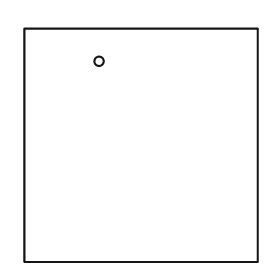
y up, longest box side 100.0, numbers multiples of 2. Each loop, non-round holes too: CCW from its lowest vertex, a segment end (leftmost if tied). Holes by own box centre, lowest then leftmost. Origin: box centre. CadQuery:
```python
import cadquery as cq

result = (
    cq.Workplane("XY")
    .moveTo(-50.0, -50.0)
    .lineTo(50.0, -50.0)
    .lineTo(50.0, 50.0)
    .lineTo(-50.0, 50.0)
    .close()
    .moveTo(-18.0, 36.0)
    .circle(2.0)
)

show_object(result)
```